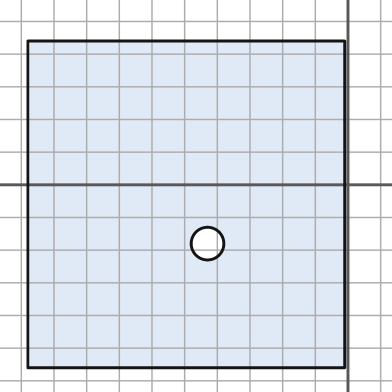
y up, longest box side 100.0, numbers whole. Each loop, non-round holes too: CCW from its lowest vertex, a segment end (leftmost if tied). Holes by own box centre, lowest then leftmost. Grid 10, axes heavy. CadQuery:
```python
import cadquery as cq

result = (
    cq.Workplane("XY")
    .moveTo(-98.0, -56.0)
    .lineTo(-1.0, -56.0)
    .lineTo(-1.0, 44.0)
    .lineTo(-98.0, 44.0)
    .close()
    .moveTo(-43.0, -18.0)
    .circle(5.0)
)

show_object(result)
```